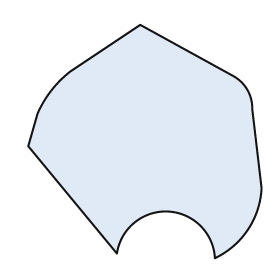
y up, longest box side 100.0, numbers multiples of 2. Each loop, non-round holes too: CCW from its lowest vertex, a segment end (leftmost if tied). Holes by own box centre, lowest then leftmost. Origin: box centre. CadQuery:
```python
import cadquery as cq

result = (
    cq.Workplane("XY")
    .moveTo(30.0, -50.0)
    .threePointArc((44.0, -38.0), (50.0, -20.0))
    .lineTo(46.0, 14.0)
    .threePointArc((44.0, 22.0), (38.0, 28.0))
    .lineTo(-2.0, 50.0)
    .lineTo(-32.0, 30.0)
    .threePointArc((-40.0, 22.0), (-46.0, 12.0))
    .lineTo(-50.0, -2.0)
    .lineTo(-12.0, -48.0)
    .threePointArc((10.0, -30.0), (30.0, -50.0))
    .close()
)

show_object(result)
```